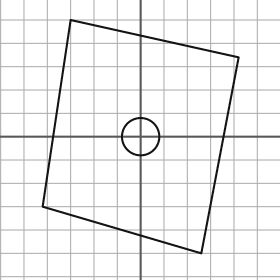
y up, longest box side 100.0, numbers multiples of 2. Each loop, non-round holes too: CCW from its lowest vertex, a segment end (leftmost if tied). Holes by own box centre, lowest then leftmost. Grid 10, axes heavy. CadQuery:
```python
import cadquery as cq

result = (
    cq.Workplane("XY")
    .moveTo(26.0, -50.0)
    .lineTo(42.0, 34.0)
    .lineTo(-30.0, 50.0)
    .lineTo(-42.0, -30.0)
    .close()
    .moveTo(0.0, 0.0)
    .circle(8.0)
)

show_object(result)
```